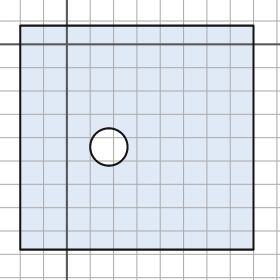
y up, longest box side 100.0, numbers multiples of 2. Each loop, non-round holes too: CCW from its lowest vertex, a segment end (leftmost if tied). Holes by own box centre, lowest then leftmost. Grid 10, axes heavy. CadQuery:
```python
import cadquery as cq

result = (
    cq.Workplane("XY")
    .moveTo(-20.0, -88.0)
    .lineTo(80.0, -88.0)
    .lineTo(80.0, 8.0)
    .lineTo(-20.0, 8.0)
    .close()
    .moveTo(18.0, -44.0)
    .circle(8.0)
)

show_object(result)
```